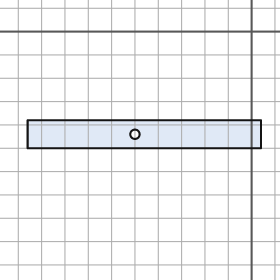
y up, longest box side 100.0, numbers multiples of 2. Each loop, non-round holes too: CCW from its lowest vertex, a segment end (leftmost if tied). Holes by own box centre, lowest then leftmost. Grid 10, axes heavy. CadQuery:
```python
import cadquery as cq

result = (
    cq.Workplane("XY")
    .moveTo(-96.0, -50.0)
    .lineTo(4.0, -50.0)
    .lineTo(4.0, -38.0)
    .lineTo(-96.0, -38.0)
    .close()
    .moveTo(-50.0, -44.0)
    .circle(2.0)
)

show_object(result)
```